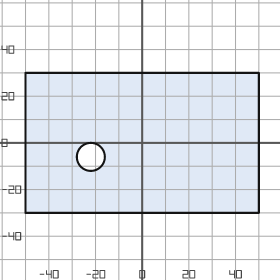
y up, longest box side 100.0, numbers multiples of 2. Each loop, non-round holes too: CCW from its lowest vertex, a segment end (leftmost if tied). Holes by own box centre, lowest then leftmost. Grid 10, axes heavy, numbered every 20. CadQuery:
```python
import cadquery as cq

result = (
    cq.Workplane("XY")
    .moveTo(-50.0, -30.0)
    .lineTo(50.0, -30.0)
    .lineTo(50.0, 30.0)
    .lineTo(-50.0, 30.0)
    .close()
    .moveTo(-22.0, -6.0)
    .circle(6.0)
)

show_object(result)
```